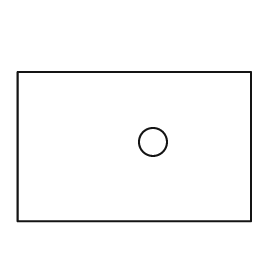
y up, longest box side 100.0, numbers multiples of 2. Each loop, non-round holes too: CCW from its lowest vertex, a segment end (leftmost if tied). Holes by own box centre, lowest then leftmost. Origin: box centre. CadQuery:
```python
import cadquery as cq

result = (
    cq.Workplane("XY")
    .moveTo(-50.0, -32.0)
    .lineTo(50.0, -32.0)
    .lineTo(50.0, 32.0)
    .lineTo(-50.0, 32.0)
    .close()
    .moveTo(8.0, 2.0)
    .circle(6.0)
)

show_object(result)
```